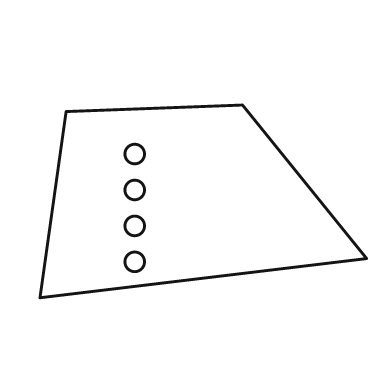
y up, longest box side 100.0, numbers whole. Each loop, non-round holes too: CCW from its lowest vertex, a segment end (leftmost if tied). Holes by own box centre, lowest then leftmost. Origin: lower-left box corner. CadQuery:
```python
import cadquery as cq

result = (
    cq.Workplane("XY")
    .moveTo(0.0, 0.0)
    .lineTo(100.0, 12.0)
    .lineTo(62.0, 59.0)
    .lineTo(8.0, 57.0)
    .close()
    .moveTo(29.0, 11.0)
    .circle(3.0)
    .moveTo(29.0, 22.0)
    .circle(3.0)
    .moveTo(29.0, 33.0)
    .circle(3.0)
    .moveTo(29.0, 44.0)
    .circle(3.0)
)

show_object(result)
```